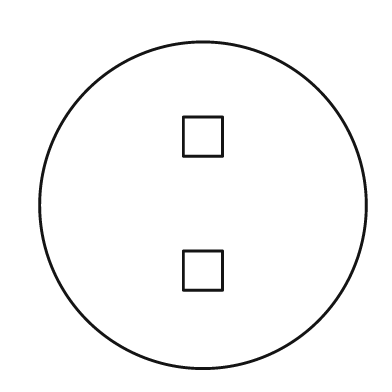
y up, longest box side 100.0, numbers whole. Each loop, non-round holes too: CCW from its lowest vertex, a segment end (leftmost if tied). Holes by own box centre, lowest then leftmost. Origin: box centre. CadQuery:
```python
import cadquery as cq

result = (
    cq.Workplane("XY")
    .moveTo(0.0, 0.0)
    .circle(50.0)
    .moveTo(-6.0, -26.0)
    .lineTo(6.0, -26.0)
    .lineTo(6.0, -14.0)
    .lineTo(-6.0, -14.0)
    .close()
    .moveTo(-6.0, 15.0)
    .lineTo(6.0, 15.0)
    .lineTo(6.0, 27.0)
    .lineTo(-6.0, 27.0)
    .close()
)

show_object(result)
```